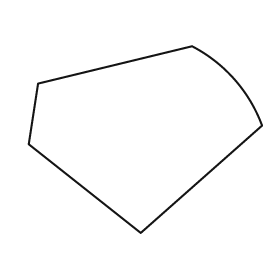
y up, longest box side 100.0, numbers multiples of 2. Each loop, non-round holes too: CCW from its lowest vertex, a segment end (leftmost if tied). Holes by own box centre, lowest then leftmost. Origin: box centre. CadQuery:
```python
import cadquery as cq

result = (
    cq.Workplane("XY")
    .moveTo(-2.0, -40.0)
    .lineTo(50.0, 6.0)
    .threePointArc((38.0, 26.0), (20.0, 40.0))
    .lineTo(-46.0, 24.0)
    .lineTo(-50.0, -2.0)
    .close()
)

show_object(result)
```